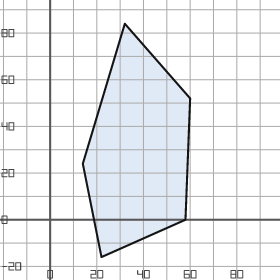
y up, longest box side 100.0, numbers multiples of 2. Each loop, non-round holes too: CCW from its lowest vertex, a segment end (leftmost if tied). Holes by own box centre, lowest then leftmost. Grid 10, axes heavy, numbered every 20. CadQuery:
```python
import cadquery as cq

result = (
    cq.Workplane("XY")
    .moveTo(22.0, -16.0)
    .lineTo(58.0, 0.0)
    .lineTo(60.0, 52.0)
    .lineTo(32.0, 84.0)
    .lineTo(14.0, 24.0)
    .close()
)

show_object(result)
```